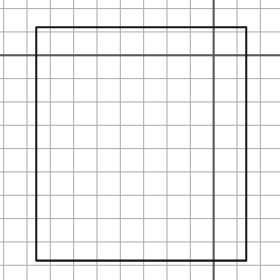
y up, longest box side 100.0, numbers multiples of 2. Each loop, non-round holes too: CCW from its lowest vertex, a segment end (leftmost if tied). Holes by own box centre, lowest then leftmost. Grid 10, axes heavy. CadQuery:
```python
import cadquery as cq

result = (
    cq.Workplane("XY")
    .moveTo(-76.0, -88.0)
    .lineTo(14.0, -88.0)
    .lineTo(14.0, 12.0)
    .lineTo(-76.0, 12.0)
    .close()
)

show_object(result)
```